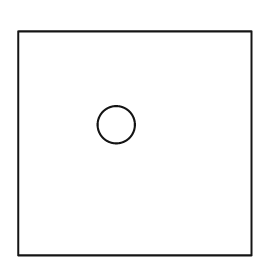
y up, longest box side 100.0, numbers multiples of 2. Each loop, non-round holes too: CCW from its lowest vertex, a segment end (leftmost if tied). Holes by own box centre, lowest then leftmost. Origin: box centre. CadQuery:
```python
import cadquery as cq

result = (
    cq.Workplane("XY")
    .moveTo(-50.0, -48.0)
    .lineTo(50.0, -48.0)
    .lineTo(50.0, 48.0)
    .lineTo(-50.0, 48.0)
    .close()
    .moveTo(-8.0, 8.0)
    .circle(8.0)
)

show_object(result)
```